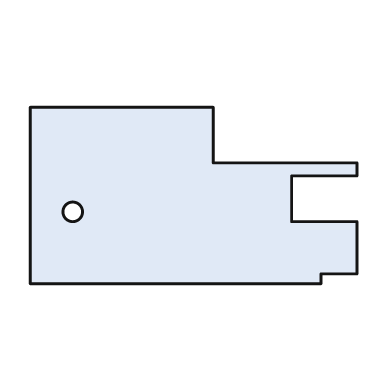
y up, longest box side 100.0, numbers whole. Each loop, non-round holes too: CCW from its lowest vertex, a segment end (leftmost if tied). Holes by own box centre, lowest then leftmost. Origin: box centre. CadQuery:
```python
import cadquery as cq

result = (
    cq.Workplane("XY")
    .moveTo(-50.0, -27.0)
    .lineTo(39.0, -27.0)
    .lineTo(39.0, -24.0)
    .lineTo(50.0, -24.0)
    .lineTo(50.0, -8.0)
    .lineTo(30.0, -8.0)
    .lineTo(30.0, 6.0)
    .lineTo(50.0, 6.0)
    .lineTo(50.0, 10.0)
    .lineTo(6.0, 10.0)
    .lineTo(6.0, 27.0)
    .lineTo(-50.0, 27.0)
    .close()
    .moveTo(-37.0, -5.0)
    .circle(3.0)
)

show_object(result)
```